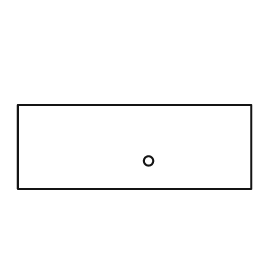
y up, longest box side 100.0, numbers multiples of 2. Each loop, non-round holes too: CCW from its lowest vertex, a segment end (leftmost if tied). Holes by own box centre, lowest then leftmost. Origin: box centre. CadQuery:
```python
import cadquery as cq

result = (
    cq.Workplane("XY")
    .moveTo(-50.0, -18.0)
    .lineTo(50.0, -18.0)
    .lineTo(50.0, 18.0)
    .lineTo(-50.0, 18.0)
    .close()
    .moveTo(6.0, -6.0)
    .circle(2.0)
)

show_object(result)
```